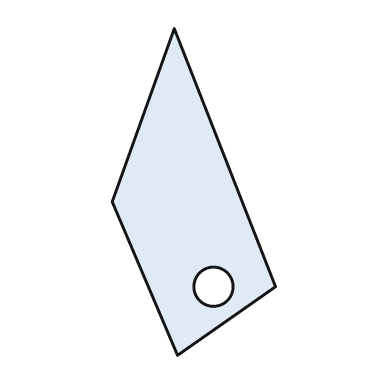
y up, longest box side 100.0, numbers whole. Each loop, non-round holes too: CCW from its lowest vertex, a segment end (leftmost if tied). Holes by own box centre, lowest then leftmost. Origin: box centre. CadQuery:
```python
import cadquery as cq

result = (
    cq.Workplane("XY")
    .moveTo(-5.0, -50.0)
    .lineTo(25.0, -29.0)
    .lineTo(-6.0, 50.0)
    .lineTo(-25.0, -3.0)
    .close()
    .moveTo(6.0, -29.0)
    .circle(6.0)
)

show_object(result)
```